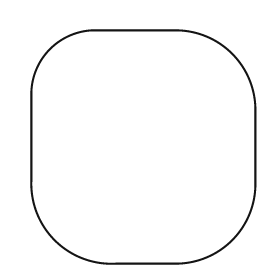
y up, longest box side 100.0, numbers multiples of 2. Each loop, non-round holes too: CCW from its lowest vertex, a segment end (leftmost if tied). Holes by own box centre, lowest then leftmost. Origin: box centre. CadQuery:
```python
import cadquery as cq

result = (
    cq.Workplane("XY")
    .moveTo(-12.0, -50.0)
    .lineTo(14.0, -50.0)
    .threePointArc((38.0, -40.0), (48.0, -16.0))
    .lineTo(48.0, 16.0)
    .threePointArc((38.0, 40.0), (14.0, 50.0))
    .lineTo(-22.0, 50.0)
    .threePointArc((-40.0, 42.0), (-48.0, 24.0))
    .lineTo(-48.0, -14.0)
    .threePointArc((-38.0, -40.0), (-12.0, -50.0))
    .close()
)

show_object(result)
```